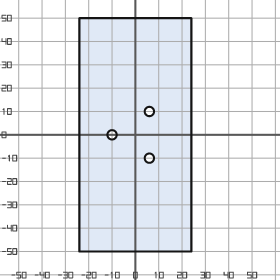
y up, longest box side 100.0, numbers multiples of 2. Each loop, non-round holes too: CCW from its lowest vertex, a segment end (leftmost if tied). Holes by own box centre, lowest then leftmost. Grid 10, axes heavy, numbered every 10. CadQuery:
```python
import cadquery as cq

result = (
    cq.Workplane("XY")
    .moveTo(-24.0, -50.0)
    .lineTo(24.0, -50.0)
    .lineTo(24.0, 50.0)
    .lineTo(-24.0, 50.0)
    .close()
    .moveTo(6.0, -10.0)
    .circle(2.0)
    .moveTo(-10.0, 0.0)
    .circle(2.0)
    .moveTo(6.0, 10.0)
    .circle(2.0)
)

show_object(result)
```